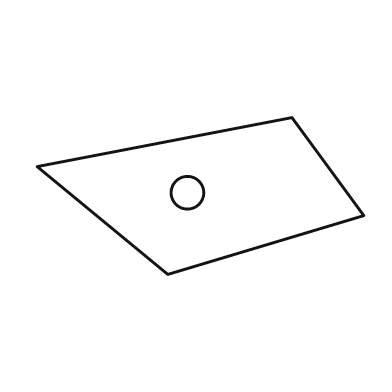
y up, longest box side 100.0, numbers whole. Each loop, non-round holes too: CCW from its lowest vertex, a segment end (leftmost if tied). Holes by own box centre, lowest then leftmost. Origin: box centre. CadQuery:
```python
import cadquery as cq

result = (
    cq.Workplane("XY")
    .moveTo(-10.0, -24.0)
    .lineTo(50.0, -6.0)
    .lineTo(28.0, 24.0)
    .lineTo(-50.0, 9.0)
    .close()
    .moveTo(-4.0, 1.0)
    .circle(5.0)
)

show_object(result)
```